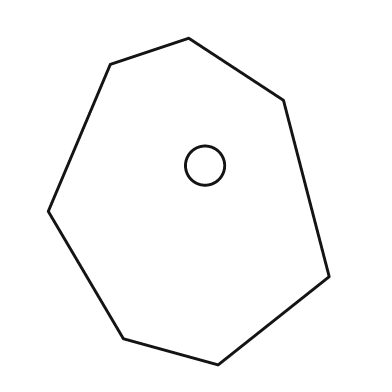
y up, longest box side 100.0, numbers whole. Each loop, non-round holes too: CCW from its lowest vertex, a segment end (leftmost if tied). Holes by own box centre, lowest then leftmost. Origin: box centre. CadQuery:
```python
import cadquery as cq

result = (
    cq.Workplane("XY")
    .moveTo(9.0, -50.0)
    .lineTo(43.0, -23.0)
    .lineTo(29.0, 31.0)
    .lineTo(0.0, 50.0)
    .lineTo(-24.0, 42.0)
    .lineTo(-43.0, -3.0)
    .lineTo(-20.0, -42.0)
    .close()
    .moveTo(5.0, 11.0)
    .circle(6.0)
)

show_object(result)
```